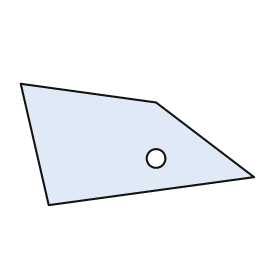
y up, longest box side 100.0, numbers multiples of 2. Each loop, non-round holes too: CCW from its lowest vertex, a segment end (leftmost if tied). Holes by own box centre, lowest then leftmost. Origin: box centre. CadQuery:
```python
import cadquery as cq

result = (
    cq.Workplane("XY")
    .moveTo(-38.0, -26.0)
    .lineTo(50.0, -14.0)
    .lineTo(8.0, 18.0)
    .lineTo(-50.0, 26.0)
    .close()
    .moveTo(8.0, -6.0)
    .circle(4.0)
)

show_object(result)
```